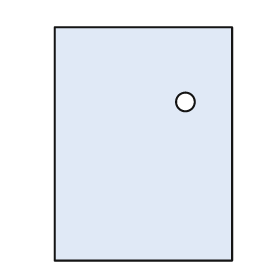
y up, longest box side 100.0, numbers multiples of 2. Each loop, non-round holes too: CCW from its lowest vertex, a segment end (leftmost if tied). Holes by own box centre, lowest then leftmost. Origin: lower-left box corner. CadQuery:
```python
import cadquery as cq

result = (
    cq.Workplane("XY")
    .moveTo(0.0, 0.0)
    .lineTo(76.0, 0.0)
    .lineTo(76.0, 100.0)
    .lineTo(0.0, 100.0)
    .close()
    .moveTo(56.0, 68.0)
    .circle(4.0)
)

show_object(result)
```